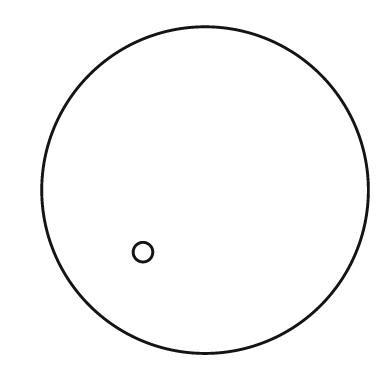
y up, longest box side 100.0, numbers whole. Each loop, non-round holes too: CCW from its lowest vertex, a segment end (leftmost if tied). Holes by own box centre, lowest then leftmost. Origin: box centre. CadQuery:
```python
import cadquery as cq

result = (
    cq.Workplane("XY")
    .moveTo(0.0, 0.0)
    .circle(50.0)
    .moveTo(-19.0, -19.0)
    .circle(3.0)
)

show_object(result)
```